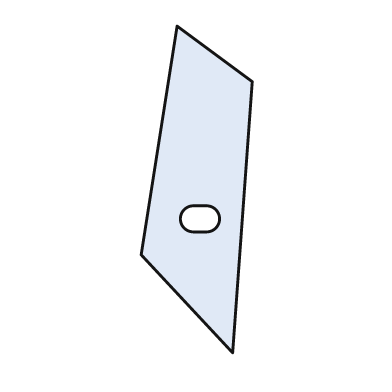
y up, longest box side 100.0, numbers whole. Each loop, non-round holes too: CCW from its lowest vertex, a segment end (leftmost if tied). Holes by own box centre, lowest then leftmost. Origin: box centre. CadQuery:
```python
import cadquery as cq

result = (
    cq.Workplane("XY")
    .moveTo(11.0, -50.0)
    .lineTo(17.0, 33.0)
    .lineTo(-6.0, 50.0)
    .lineTo(-17.0, -20.0)
    .close()
    .moveTo(-1.0, -13.0)
    .lineTo(3.0, -13.0)
    .threePointArc((7.0, -9.0), (3.0, -5.0))
    .lineTo(-1.0, -5.0)
    .threePointArc((-5.0, -9.0), (-1.0, -13.0))
    .close()
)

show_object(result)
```